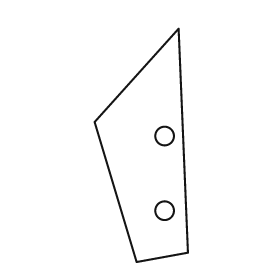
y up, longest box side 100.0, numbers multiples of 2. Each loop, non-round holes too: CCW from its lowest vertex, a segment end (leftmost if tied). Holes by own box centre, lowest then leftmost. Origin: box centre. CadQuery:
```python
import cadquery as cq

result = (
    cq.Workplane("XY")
    .moveTo(-2.0, -50.0)
    .lineTo(20.0, -46.0)
    .lineTo(16.0, 50.0)
    .lineTo(-20.0, 10.0)
    .close()
    .moveTo(10.0, -28.0)
    .circle(4.0)
    .moveTo(10.0, 4.0)
    .circle(4.0)
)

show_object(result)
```